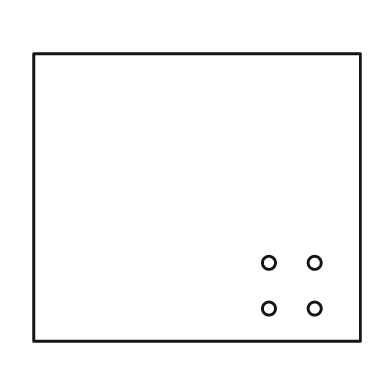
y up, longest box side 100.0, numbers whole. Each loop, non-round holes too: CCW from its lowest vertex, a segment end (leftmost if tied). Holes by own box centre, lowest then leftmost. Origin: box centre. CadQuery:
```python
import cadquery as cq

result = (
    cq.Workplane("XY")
    .moveTo(-50.0, -44.0)
    .lineTo(50.0, -44.0)
    .lineTo(50.0, 44.0)
    .lineTo(-50.0, 44.0)
    .close()
    .moveTo(22.0, -34.0)
    .circle(2.0)
    .moveTo(36.0, -34.0)
    .circle(2.0)
    .moveTo(22.0, -20.0)
    .circle(2.0)
    .moveTo(36.0, -20.0)
    .circle(2.0)
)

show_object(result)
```